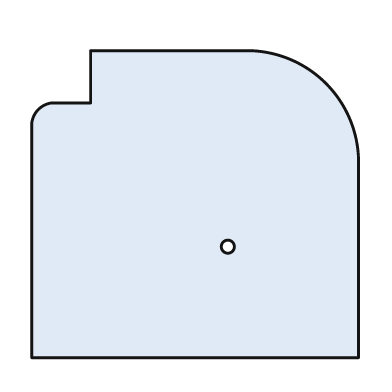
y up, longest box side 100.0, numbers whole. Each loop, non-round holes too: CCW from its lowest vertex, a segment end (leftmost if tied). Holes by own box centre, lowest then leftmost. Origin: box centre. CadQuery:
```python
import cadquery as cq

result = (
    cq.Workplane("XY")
    .moveTo(-50.0, -47.0)
    .lineTo(50.0, -47.0)
    .lineTo(50.0, 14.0)
    .threePointArc((40.0, 37.0), (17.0, 47.0))
    .lineTo(-32.0, 47.0)
    .lineTo(-32.0, 31.0)
    .lineTo(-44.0, 31.0)
    .threePointArc((-48.0, 29.0), (-50.0, 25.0))
    .close()
    .moveTo(10.0, -13.0)
    .circle(2.0)
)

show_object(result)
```